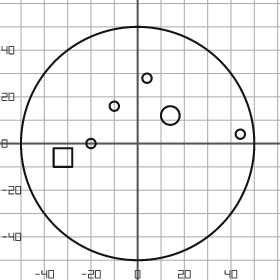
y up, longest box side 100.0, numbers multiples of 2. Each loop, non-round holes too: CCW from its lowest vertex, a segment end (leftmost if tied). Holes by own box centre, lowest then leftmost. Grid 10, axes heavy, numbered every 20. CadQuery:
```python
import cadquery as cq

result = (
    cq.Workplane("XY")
    .moveTo(0.0, 0.0)
    .circle(50.0)
    .moveTo(-36.0, -10.0)
    .lineTo(-28.0, -10.0)
    .lineTo(-28.0, -2.0)
    .lineTo(-36.0, -2.0)
    .close()
    .moveTo(-20.0, 0.0)
    .circle(2.0)
    .moveTo(44.0, 4.0)
    .circle(2.0)
    .moveTo(14.0, 12.0)
    .circle(4.0)
    .moveTo(-10.0, 16.0)
    .circle(2.0)
    .moveTo(4.0, 28.0)
    .circle(2.0)
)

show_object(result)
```